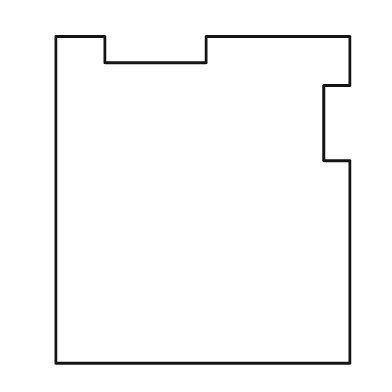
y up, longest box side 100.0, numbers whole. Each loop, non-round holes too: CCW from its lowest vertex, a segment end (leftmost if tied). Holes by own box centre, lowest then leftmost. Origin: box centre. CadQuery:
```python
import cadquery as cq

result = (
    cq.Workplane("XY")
    .moveTo(-45.0, -50.0)
    .lineTo(45.0, -50.0)
    .lineTo(45.0, 12.0)
    .lineTo(37.0, 12.0)
    .lineTo(37.0, 35.0)
    .lineTo(45.0, 35.0)
    .lineTo(45.0, 50.0)
    .lineTo(1.0, 50.0)
    .lineTo(1.0, 42.0)
    .lineTo(-30.0, 42.0)
    .lineTo(-30.0, 50.0)
    .lineTo(-45.0, 50.0)
    .close()
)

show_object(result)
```